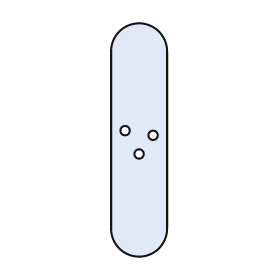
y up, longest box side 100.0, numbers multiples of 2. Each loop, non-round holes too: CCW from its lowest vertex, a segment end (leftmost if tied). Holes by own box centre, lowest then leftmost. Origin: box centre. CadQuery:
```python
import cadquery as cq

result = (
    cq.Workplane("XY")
    .moveTo(-12.0, -38.0)
    .threePointArc((0.0, -50.0), (12.0, -38.0))
    .lineTo(12.0, 38.0)
    .threePointArc((0.0, 50.0), (-12.0, 38.0))
    .close()
    .moveTo(0.0, -6.0)
    .circle(2.0)
    .moveTo(6.0, 2.0)
    .circle(2.0)
    .moveTo(-6.0, 4.0)
    .circle(2.0)
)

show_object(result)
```